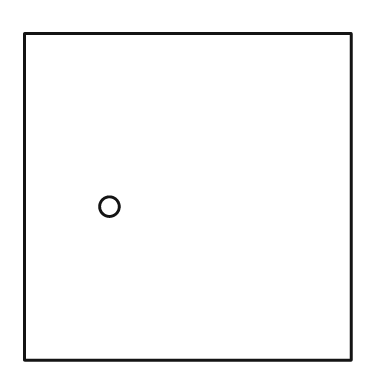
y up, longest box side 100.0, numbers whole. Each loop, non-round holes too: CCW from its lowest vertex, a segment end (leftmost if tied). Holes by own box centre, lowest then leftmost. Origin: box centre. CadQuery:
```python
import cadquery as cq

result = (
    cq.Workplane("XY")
    .moveTo(-50.0, -50.0)
    .lineTo(50.0, -50.0)
    .lineTo(50.0, 50.0)
    .lineTo(-50.0, 50.0)
    .close()
    .moveTo(-24.0, -3.0)
    .circle(3.0)
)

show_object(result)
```